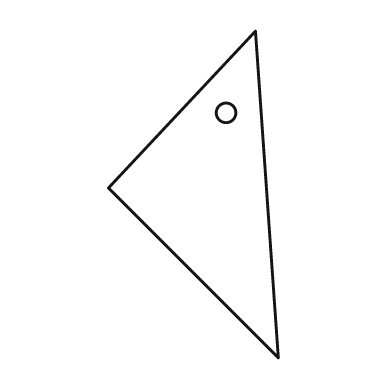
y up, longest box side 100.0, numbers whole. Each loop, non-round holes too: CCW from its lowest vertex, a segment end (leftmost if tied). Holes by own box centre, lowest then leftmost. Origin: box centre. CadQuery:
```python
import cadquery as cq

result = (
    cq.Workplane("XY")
    .moveTo(26.0, -50.0)
    .lineTo(19.0, 50.0)
    .lineTo(-26.0, 2.0)
    .close()
    .moveTo(10.0, 25.0)
    .circle(3.0)
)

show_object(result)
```